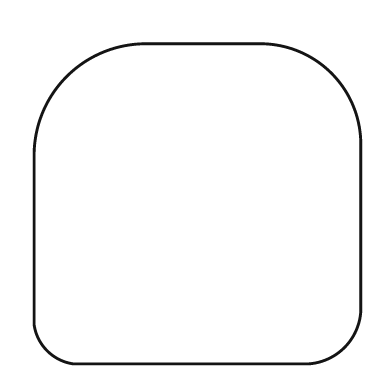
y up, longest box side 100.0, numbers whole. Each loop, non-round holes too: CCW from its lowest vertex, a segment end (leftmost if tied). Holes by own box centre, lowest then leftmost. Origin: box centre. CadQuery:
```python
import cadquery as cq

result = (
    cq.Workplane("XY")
    .moveTo(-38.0, -49.0)
    .lineTo(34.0, -49.0)
    .threePointArc((45.0, -44.0), (50.0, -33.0))
    .lineTo(50.0, 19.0)
    .threePointArc((41.0, 40.0), (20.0, 49.0))
    .lineTo(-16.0, 49.0)
    .threePointArc((-40.0, 39.0), (-50.0, 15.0))
    .lineTo(-50.0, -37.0)
    .threePointArc((-46.0, -45.0), (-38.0, -49.0))
    .close()
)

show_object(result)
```